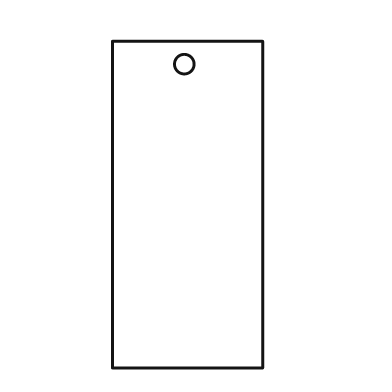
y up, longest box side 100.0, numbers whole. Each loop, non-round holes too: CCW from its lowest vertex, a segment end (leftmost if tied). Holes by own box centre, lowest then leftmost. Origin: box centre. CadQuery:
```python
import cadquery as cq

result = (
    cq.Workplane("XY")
    .moveTo(-23.0, -50.0)
    .lineTo(23.0, -50.0)
    .lineTo(23.0, 50.0)
    .lineTo(-23.0, 50.0)
    .close()
    .moveTo(-1.0, 43.0)
    .circle(3.0)
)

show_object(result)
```